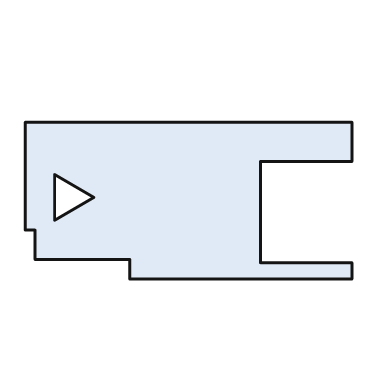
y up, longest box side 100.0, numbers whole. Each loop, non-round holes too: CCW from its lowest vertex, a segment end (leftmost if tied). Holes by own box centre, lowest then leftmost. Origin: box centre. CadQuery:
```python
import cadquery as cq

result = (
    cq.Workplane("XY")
    .moveTo(-18.0, -24.0)
    .lineTo(50.0, -24.0)
    .lineTo(50.0, -19.0)
    .lineTo(22.0, -19.0)
    .lineTo(22.0, 12.0)
    .lineTo(50.0, 12.0)
    .lineTo(50.0, 24.0)
    .lineTo(-50.0, 24.0)
    .lineTo(-50.0, -9.0)
    .lineTo(-47.0, -9.0)
    .lineTo(-47.0, -18.0)
    .lineTo(-18.0, -18.0)
    .close()
    .moveTo(-41.0, -6.0)
    .lineTo(-29.0, 1.0)
    .lineTo(-41.0, 8.0)
    .close()
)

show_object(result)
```